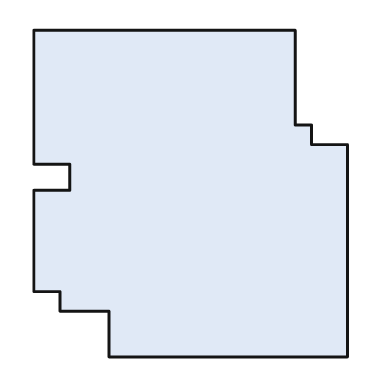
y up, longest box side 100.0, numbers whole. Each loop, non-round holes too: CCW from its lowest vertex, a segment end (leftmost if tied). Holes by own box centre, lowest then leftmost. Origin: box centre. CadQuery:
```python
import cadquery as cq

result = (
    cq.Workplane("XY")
    .moveTo(-25.0, -50.0)
    .lineTo(48.0, -50.0)
    .lineTo(48.0, 15.0)
    .lineTo(37.0, 15.0)
    .lineTo(37.0, 21.0)
    .lineTo(32.0, 21.0)
    .lineTo(32.0, 50.0)
    .lineTo(-48.0, 50.0)
    .lineTo(-48.0, 9.0)
    .lineTo(-37.0, 9.0)
    .lineTo(-37.0, 1.0)
    .lineTo(-48.0, 1.0)
    .lineTo(-48.0, -30.0)
    .lineTo(-40.0, -30.0)
    .lineTo(-40.0, -36.0)
    .lineTo(-25.0, -36.0)
    .close()
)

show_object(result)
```